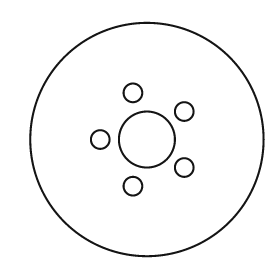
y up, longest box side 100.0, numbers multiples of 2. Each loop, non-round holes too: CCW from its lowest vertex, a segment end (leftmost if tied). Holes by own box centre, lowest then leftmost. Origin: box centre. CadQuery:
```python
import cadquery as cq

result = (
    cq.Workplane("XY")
    .moveTo(0.0, 0.0)
    .circle(50.0)
    .moveTo(-6.0, -20.0)
    .circle(4.0)
    .moveTo(16.0, -12.0)
    .circle(4.0)
    .moveTo(-20.0, 0.0)
    .circle(4.0)
    .moveTo(0.0, 0.0)
    .circle(12.0)
    .moveTo(16.0, 12.0)
    .circle(4.0)
    .moveTo(-6.0, 20.0)
    .circle(4.0)
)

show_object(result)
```